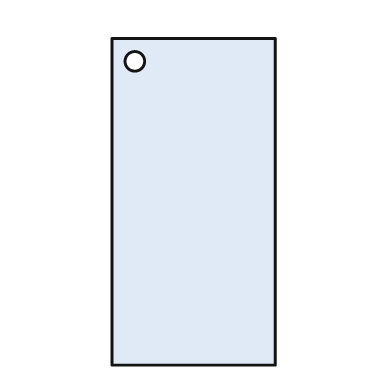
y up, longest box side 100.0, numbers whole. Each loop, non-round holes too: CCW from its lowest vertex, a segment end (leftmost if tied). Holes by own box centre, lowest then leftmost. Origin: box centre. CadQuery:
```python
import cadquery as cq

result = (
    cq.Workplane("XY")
    .moveTo(-25.0, -50.0)
    .lineTo(25.0, -50.0)
    .lineTo(25.0, 50.0)
    .lineTo(-25.0, 50.0)
    .close()
    .moveTo(-18.0, 43.0)
    .circle(3.0)
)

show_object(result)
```